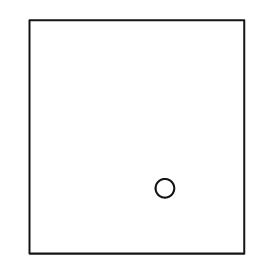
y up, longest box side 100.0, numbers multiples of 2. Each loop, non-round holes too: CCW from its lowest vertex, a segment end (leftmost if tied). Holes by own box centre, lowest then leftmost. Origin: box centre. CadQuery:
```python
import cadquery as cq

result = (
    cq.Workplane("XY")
    .moveTo(-46.0, -50.0)
    .lineTo(46.0, -50.0)
    .lineTo(46.0, 50.0)
    .lineTo(-46.0, 50.0)
    .close()
    .moveTo(12.0, -22.0)
    .circle(4.0)
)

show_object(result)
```